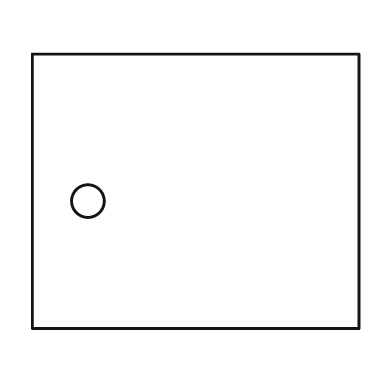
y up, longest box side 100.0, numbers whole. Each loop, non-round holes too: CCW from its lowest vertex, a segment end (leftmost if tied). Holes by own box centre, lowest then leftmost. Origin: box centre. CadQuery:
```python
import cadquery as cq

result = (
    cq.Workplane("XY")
    .moveTo(-50.0, -42.0)
    .lineTo(50.0, -42.0)
    .lineTo(50.0, 42.0)
    .lineTo(-50.0, 42.0)
    .close()
    .moveTo(-33.0, -3.0)
    .circle(5.0)
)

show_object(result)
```